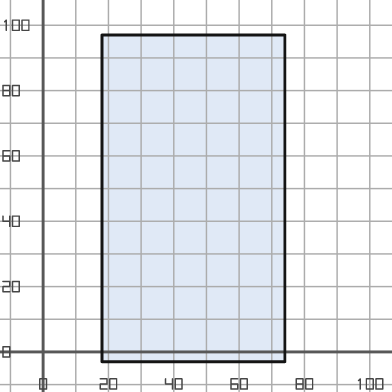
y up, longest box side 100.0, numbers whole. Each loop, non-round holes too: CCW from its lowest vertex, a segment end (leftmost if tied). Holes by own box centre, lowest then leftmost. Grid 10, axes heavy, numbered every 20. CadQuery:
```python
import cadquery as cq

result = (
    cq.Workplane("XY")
    .moveTo(18.0, -3.0)
    .lineTo(74.0, -3.0)
    .lineTo(74.0, 97.0)
    .lineTo(18.0, 97.0)
    .close()
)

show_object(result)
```